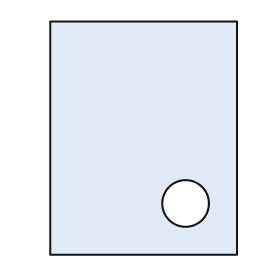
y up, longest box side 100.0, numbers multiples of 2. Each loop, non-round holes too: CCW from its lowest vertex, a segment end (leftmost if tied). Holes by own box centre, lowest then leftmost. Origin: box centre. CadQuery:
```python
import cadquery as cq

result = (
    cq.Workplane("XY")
    .moveTo(-40.0, -50.0)
    .lineTo(40.0, -50.0)
    .lineTo(40.0, 50.0)
    .lineTo(-40.0, 50.0)
    .close()
    .moveTo(18.0, -28.0)
    .circle(10.0)
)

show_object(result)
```